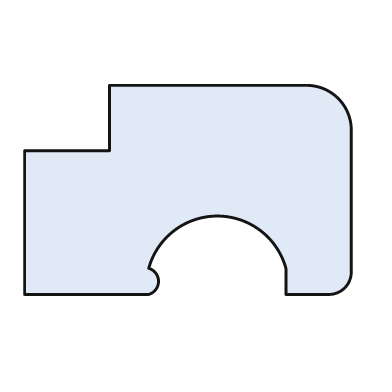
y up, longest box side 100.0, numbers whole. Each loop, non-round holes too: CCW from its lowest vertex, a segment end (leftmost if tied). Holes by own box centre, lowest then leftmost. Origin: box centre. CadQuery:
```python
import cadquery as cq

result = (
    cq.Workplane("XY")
    .moveTo(-50.0, -32.0)
    .lineTo(-12.0, -32.0)
    .threePointArc((-9.0, -28.0), (-12.0, -24.0))
    .threePointArc((9.0, -8.0), (30.0, -24.0))
    .lineTo(30.0, -32.0)
    .lineTo(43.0, -32.0)
    .threePointArc((48.0, -30.0), (50.0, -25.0))
    .lineTo(50.0, 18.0)
    .threePointArc((46.0, 28.0), (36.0, 32.0))
    .lineTo(-24.0, 32.0)
    .lineTo(-24.0, 12.0)
    .lineTo(-50.0, 12.0)
    .close()
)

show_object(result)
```